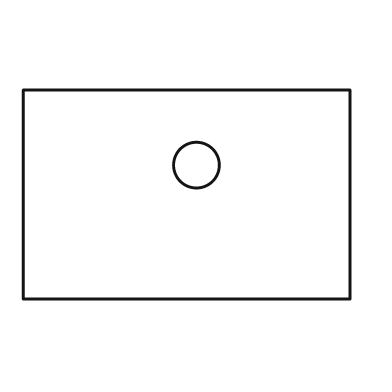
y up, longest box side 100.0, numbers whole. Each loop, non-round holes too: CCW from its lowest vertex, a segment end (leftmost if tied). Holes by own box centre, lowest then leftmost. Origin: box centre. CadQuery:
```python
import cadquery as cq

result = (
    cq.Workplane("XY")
    .moveTo(-50.0, -32.0)
    .lineTo(50.0, -32.0)
    .lineTo(50.0, 32.0)
    .lineTo(-50.0, 32.0)
    .close()
    .moveTo(3.0, 9.0)
    .circle(7.0)
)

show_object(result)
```